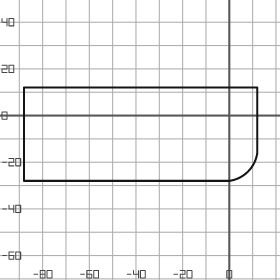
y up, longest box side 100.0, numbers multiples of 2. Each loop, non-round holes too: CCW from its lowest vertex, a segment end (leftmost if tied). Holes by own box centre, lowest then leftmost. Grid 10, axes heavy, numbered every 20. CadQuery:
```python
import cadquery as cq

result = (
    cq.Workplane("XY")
    .moveTo(-88.0, -28.0)
    .lineTo(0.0, -28.0)
    .threePointArc((8.0, -24.0), (12.0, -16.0))
    .lineTo(12.0, 12.0)
    .lineTo(-88.0, 12.0)
    .close()
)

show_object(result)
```